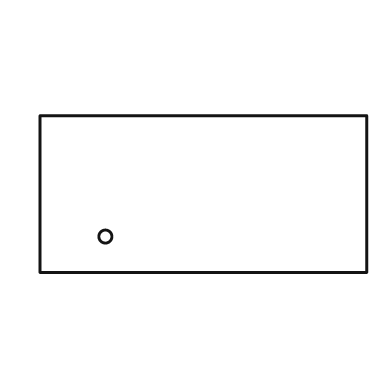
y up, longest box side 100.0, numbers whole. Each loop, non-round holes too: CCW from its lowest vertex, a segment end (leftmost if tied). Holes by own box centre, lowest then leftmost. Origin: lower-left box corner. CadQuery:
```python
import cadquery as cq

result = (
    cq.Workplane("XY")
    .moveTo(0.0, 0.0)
    .lineTo(100.0, 0.0)
    .lineTo(100.0, 48.0)
    .lineTo(0.0, 48.0)
    .close()
    .moveTo(20.0, 11.0)
    .circle(2.0)
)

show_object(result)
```